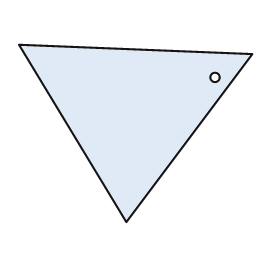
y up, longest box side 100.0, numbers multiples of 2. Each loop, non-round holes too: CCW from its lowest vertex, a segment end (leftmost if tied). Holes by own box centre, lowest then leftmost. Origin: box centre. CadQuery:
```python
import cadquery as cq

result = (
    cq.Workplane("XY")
    .moveTo(-4.0, -38.0)
    .lineTo(50.0, 34.0)
    .lineTo(-50.0, 38.0)
    .close()
    .moveTo(34.0, 24.0)
    .circle(2.0)
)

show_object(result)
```